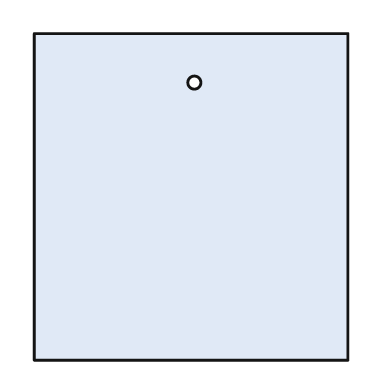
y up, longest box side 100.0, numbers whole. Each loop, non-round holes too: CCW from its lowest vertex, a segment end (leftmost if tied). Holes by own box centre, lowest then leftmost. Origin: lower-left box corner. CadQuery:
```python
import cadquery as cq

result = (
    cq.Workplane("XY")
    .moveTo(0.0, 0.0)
    .lineTo(96.0, 0.0)
    .lineTo(96.0, 100.0)
    .lineTo(0.0, 100.0)
    .close()
    .moveTo(49.0, 85.0)
    .circle(2.0)
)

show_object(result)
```